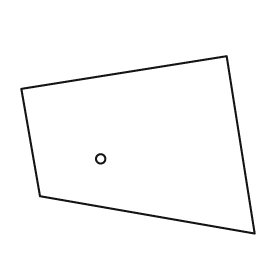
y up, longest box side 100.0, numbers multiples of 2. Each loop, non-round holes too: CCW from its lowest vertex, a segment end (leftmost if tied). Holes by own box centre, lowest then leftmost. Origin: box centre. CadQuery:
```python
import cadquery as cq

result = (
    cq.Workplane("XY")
    .moveTo(50.0, -38.0)
    .lineTo(38.0, 38.0)
    .lineTo(-50.0, 24.0)
    .lineTo(-42.0, -22.0)
    .close()
    .moveTo(-16.0, -6.0)
    .circle(2.0)
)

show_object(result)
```